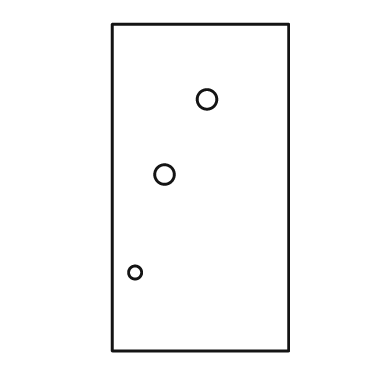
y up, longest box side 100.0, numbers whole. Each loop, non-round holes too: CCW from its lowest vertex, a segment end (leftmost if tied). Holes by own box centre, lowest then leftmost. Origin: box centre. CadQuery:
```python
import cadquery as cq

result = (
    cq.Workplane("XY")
    .moveTo(-27.0, -50.0)
    .lineTo(27.0, -50.0)
    .lineTo(27.0, 50.0)
    .lineTo(-27.0, 50.0)
    .close()
    .moveTo(-20.0, -26.0)
    .circle(2.0)
    .moveTo(-11.0, 4.0)
    .circle(3.0)
    .moveTo(2.0, 27.0)
    .circle(3.0)
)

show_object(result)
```